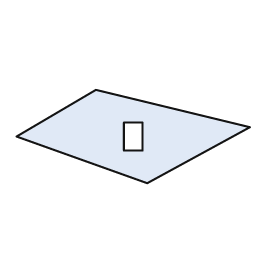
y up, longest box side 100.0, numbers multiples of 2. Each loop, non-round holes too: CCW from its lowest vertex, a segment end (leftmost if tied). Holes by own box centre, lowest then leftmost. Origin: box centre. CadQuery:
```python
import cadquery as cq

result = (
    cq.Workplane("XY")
    .moveTo(6.0, -20.0)
    .lineTo(50.0, 4.0)
    .lineTo(-16.0, 20.0)
    .lineTo(-50.0, 0.0)
    .close()
    .moveTo(-4.0, -6.0)
    .lineTo(4.0, -6.0)
    .lineTo(4.0, 6.0)
    .lineTo(-4.0, 6.0)
    .close()
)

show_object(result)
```